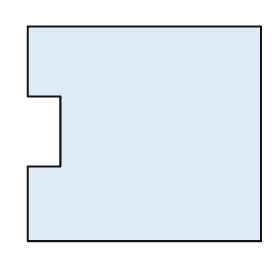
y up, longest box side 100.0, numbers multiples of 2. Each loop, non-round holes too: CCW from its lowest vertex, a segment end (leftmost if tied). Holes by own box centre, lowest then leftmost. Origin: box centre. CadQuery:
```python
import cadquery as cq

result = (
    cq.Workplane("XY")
    .moveTo(-50.0, -46.0)
    .lineTo(50.0, -46.0)
    .lineTo(50.0, 46.0)
    .lineTo(-50.0, 46.0)
    .lineTo(-50.0, 16.0)
    .lineTo(-36.0, 16.0)
    .lineTo(-36.0, -14.0)
    .lineTo(-50.0, -14.0)
    .close()
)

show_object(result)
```